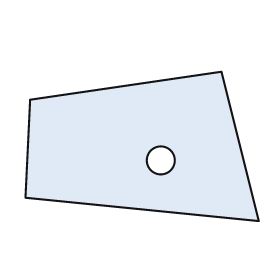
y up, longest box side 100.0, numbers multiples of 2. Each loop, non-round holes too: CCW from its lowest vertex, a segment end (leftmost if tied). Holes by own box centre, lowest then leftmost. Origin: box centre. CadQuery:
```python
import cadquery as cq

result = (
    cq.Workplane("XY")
    .moveTo(50.0, -32.0)
    .lineTo(34.0, 32.0)
    .lineTo(-48.0, 20.0)
    .lineTo(-50.0, -22.0)
    .close()
    .moveTo(8.0, -6.0)
    .circle(6.0)
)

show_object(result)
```